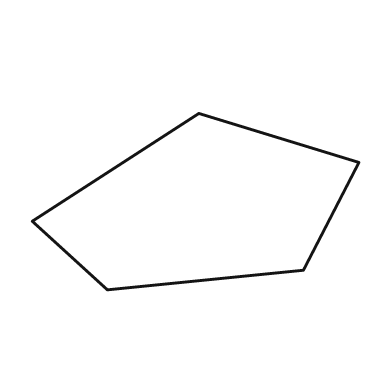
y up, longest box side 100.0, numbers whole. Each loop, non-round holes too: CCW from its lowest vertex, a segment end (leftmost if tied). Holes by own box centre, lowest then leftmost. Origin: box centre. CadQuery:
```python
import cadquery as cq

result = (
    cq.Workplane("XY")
    .moveTo(-27.0, -27.0)
    .lineTo(33.0, -21.0)
    .lineTo(50.0, 12.0)
    .lineTo(1.0, 27.0)
    .lineTo(-50.0, -6.0)
    .close()
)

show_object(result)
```